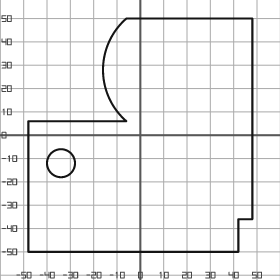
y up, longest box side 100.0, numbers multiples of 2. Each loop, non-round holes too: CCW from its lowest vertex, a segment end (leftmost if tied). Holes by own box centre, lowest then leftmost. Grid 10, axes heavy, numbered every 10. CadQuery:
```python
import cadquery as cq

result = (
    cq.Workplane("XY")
    .moveTo(-48.0, -50.0)
    .lineTo(42.0, -50.0)
    .lineTo(42.0, -36.0)
    .lineTo(48.0, -36.0)
    .lineTo(48.0, 50.0)
    .lineTo(-6.0, 50.0)
    .threePointArc((-16.0, 28.0), (-6.0, 6.0))
    .lineTo(-48.0, 6.0)
    .close()
    .moveTo(-34.0, -12.0)
    .circle(6.0)
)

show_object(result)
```